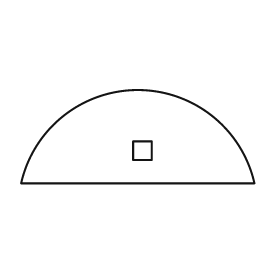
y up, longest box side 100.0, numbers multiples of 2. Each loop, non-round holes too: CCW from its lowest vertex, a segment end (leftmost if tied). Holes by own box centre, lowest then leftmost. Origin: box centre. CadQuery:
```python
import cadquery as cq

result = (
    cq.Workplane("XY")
    .moveTo(-50.0, -20.0)
    .lineTo(50.0, -20.0)
    .threePointArc((0.0, 20.0), (-50.0, -20.0))
    .close()
    .moveTo(-2.0, -10.0)
    .lineTo(6.0, -10.0)
    .lineTo(6.0, -2.0)
    .lineTo(-2.0, -2.0)
    .close()
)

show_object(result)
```